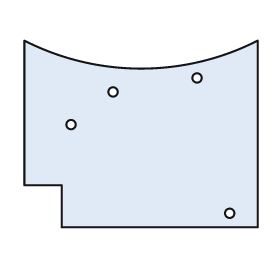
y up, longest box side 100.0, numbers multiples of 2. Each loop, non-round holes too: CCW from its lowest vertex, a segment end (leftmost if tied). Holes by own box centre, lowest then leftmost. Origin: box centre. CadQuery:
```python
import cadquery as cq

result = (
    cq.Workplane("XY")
    .moveTo(-34.0, -40.0)
    .lineTo(50.0, -40.0)
    .lineTo(50.0, 40.0)
    .threePointArc((0.0, 28.0), (-50.0, 40.0))
    .lineTo(-50.0, -22.0)
    .lineTo(-34.0, -22.0)
    .close()
    .moveTo(38.0, -34.0)
    .circle(2.0)
    .moveTo(-30.0, 4.0)
    .circle(2.0)
    .moveTo(-12.0, 18.0)
    .circle(2.0)
    .moveTo(24.0, 24.0)
    .circle(2.0)
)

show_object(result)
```